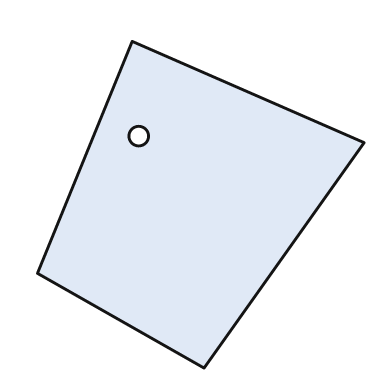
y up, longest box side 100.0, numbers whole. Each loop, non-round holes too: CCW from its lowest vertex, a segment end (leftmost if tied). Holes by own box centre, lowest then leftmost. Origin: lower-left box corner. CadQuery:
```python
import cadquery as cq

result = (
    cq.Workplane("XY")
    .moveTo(51.0, 0.0)
    .lineTo(100.0, 69.0)
    .lineTo(29.0, 100.0)
    .lineTo(0.0, 29.0)
    .close()
    .moveTo(31.0, 71.0)
    .circle(3.0)
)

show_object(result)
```